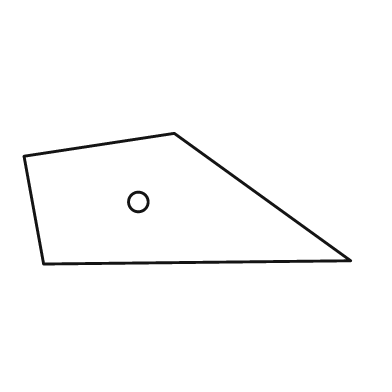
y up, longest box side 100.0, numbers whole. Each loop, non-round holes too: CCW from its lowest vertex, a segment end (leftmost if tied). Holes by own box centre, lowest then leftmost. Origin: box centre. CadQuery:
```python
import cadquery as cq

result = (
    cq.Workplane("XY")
    .moveTo(-44.0, -20.0)
    .lineTo(50.0, -19.0)
    .lineTo(-4.0, 20.0)
    .lineTo(-50.0, 13.0)
    .close()
    .moveTo(-15.0, -1.0)
    .circle(3.0)
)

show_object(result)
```